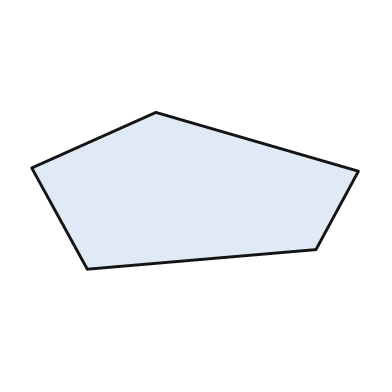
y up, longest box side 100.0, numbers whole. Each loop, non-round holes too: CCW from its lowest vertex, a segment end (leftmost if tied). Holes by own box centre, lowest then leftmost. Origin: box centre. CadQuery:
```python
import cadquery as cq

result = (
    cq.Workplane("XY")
    .moveTo(-33.0, -24.0)
    .lineTo(37.0, -18.0)
    .lineTo(50.0, 6.0)
    .lineTo(-12.0, 24.0)
    .lineTo(-50.0, 7.0)
    .close()
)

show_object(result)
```